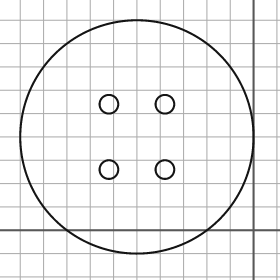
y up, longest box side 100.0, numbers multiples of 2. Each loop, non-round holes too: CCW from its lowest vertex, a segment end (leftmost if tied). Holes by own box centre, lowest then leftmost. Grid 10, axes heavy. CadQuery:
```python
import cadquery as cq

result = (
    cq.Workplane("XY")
    .moveTo(-50.0, 40.0)
    .circle(50.0)
    .moveTo(-62.0, 26.0)
    .circle(4.0)
    .moveTo(-38.0, 26.0)
    .circle(4.0)
    .moveTo(-62.0, 54.0)
    .circle(4.0)
    .moveTo(-38.0, 54.0)
    .circle(4.0)
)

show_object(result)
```